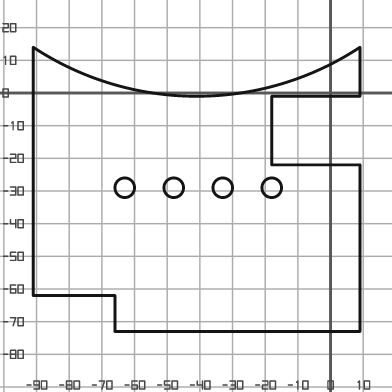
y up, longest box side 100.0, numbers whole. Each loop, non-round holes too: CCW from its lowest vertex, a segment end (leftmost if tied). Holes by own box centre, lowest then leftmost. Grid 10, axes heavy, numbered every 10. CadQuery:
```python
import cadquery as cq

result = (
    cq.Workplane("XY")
    .moveTo(-66.0, -73.0)
    .lineTo(9.0, -73.0)
    .lineTo(9.0, -22.0)
    .lineTo(-18.0, -22.0)
    .lineTo(-18.0, -1.0)
    .lineTo(9.0, -1.0)
    .lineTo(9.0, 14.0)
    .threePointArc((-41.0, -1.0), (-91.0, 14.0))
    .lineTo(-91.0, -62.0)
    .lineTo(-66.0, -62.0)
    .close()
    .moveTo(-63.0, -29.0)
    .circle(3.0)
    .moveTo(-48.0, -29.0)
    .circle(3.0)
    .moveTo(-33.0, -29.0)
    .circle(3.0)
    .moveTo(-18.0, -29.0)
    .circle(3.0)
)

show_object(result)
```